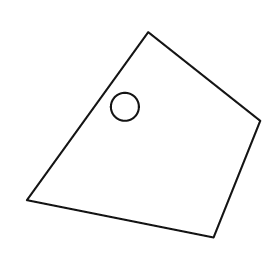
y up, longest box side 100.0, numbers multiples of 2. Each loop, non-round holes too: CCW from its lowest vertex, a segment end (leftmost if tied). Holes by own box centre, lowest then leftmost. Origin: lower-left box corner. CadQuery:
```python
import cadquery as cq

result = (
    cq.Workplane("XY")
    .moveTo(80.0, 0.0)
    .lineTo(100.0, 50.0)
    .lineTo(52.0, 88.0)
    .lineTo(0.0, 16.0)
    .close()
    .moveTo(42.0, 56.0)
    .circle(6.0)
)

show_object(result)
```